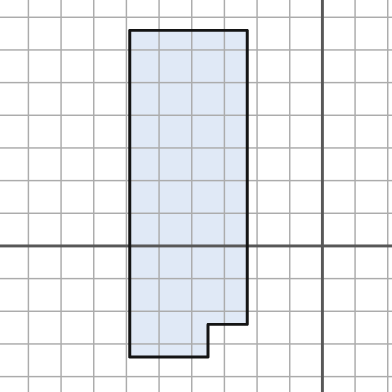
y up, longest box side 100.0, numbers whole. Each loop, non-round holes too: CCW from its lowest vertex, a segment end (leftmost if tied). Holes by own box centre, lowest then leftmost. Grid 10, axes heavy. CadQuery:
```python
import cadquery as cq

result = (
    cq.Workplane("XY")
    .moveTo(-59.0, -34.0)
    .lineTo(-35.0, -34.0)
    .lineTo(-35.0, -24.0)
    .lineTo(-23.0, -24.0)
    .lineTo(-23.0, 66.0)
    .lineTo(-59.0, 66.0)
    .close()
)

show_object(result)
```